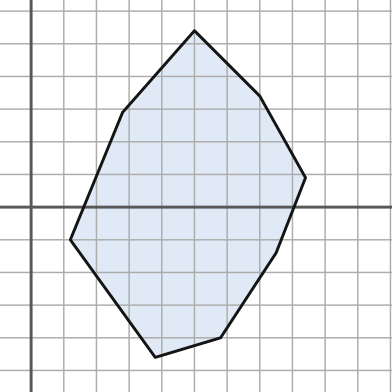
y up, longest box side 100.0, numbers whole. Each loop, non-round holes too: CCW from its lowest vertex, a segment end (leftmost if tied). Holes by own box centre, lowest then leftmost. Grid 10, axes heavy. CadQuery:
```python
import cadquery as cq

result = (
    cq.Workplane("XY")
    .moveTo(38.0, -46.0)
    .lineTo(58.0, -40.0)
    .lineTo(75.0, -14.0)
    .lineTo(84.0, 9.0)
    .lineTo(70.0, 34.0)
    .lineTo(50.0, 54.0)
    .lineTo(28.0, 29.0)
    .lineTo(12.0, -10.0)
    .close()
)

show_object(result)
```